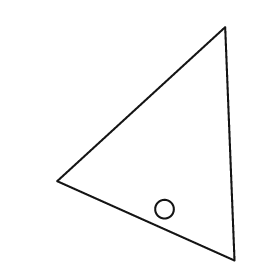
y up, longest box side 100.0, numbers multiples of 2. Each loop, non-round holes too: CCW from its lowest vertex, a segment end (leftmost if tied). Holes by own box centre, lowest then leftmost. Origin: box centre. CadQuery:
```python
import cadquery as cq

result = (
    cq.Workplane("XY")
    .moveTo(38.0, -50.0)
    .lineTo(34.0, 50.0)
    .lineTo(-38.0, -16.0)
    .close()
    .moveTo(8.0, -28.0)
    .circle(4.0)
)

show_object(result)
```